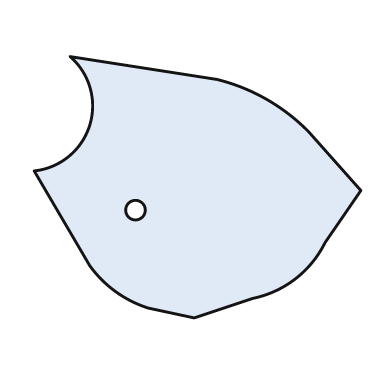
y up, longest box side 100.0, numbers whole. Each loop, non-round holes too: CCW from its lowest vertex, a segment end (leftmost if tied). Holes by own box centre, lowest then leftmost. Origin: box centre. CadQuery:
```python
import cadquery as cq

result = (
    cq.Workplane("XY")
    .moveTo(-1.0, -40.0)
    .lineTo(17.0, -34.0)
    .threePointArc((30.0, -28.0), (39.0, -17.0))
    .lineTo(50.0, -1.0)
    .lineTo(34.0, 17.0)
    .threePointArc((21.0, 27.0), (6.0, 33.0))
    .lineTo(-39.0, 40.0)
    .threePointArc((-33.0, 19.0), (-50.0, 5.0))
    .lineTo(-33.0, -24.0)
    .threePointArc((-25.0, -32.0), (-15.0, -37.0))
    .close()
    .moveTo(-19.0, -7.0)
    .circle(3.0)
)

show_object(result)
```